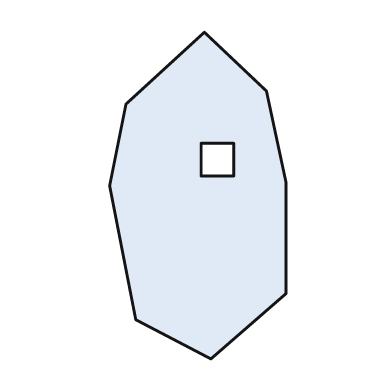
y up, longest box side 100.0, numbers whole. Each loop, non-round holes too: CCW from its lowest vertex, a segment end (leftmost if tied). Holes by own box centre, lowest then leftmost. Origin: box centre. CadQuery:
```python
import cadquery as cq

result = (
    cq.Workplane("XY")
    .moveTo(4.0, -50.0)
    .lineTo(27.0, -30.0)
    .lineTo(27.0, 4.0)
    .lineTo(21.0, 32.0)
    .lineTo(2.0, 50.0)
    .lineTo(-22.0, 28.0)
    .lineTo(-27.0, 3.0)
    .lineTo(-19.0, -38.0)
    .close()
    .moveTo(1.0, 6.0)
    .lineTo(11.0, 6.0)
    .lineTo(11.0, 16.0)
    .lineTo(1.0, 16.0)
    .close()
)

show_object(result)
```